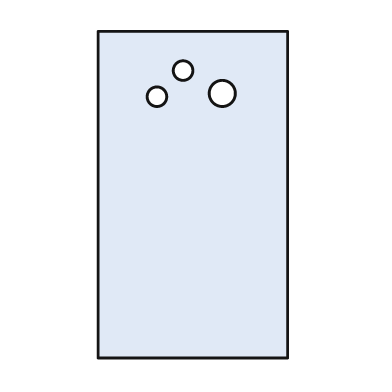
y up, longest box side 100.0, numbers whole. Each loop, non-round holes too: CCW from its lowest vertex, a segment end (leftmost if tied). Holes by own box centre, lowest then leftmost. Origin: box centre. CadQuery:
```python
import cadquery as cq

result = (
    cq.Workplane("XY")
    .moveTo(-29.0, -50.0)
    .lineTo(29.0, -50.0)
    .lineTo(29.0, 50.0)
    .lineTo(-29.0, 50.0)
    .close()
    .moveTo(-11.0, 30.0)
    .circle(3.0)
    .moveTo(9.0, 31.0)
    .circle(4.0)
    .moveTo(-3.0, 38.0)
    .circle(3.0)
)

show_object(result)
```